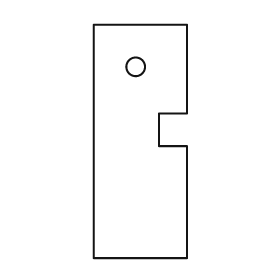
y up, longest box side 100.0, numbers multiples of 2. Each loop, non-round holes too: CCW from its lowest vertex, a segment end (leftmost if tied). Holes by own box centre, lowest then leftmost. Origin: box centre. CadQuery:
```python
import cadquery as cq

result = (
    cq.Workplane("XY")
    .moveTo(-20.0, -50.0)
    .lineTo(20.0, -50.0)
    .lineTo(20.0, -2.0)
    .lineTo(8.0, -2.0)
    .lineTo(8.0, 12.0)
    .lineTo(20.0, 12.0)
    .lineTo(20.0, 50.0)
    .lineTo(-20.0, 50.0)
    .close()
    .moveTo(-2.0, 32.0)
    .circle(4.0)
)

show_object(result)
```